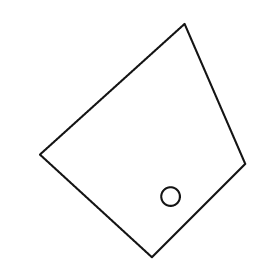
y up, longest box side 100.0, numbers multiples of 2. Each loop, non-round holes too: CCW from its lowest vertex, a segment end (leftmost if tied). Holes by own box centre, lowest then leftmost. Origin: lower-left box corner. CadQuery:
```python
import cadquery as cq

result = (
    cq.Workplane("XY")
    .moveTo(48.0, 0.0)
    .lineTo(88.0, 40.0)
    .lineTo(62.0, 100.0)
    .lineTo(0.0, 44.0)
    .close()
    .moveTo(56.0, 26.0)
    .circle(4.0)
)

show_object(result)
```